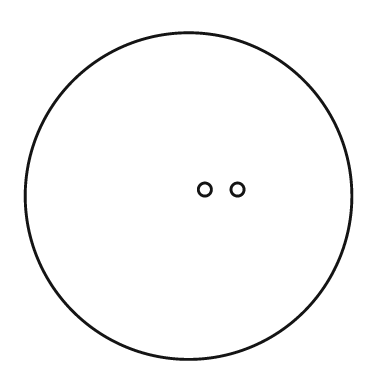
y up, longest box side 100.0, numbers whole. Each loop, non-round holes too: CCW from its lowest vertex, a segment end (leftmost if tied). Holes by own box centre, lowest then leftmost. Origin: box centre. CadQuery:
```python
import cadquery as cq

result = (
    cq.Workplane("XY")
    .moveTo(0.0, 0.0)
    .circle(50.0)
    .moveTo(5.0, 2.0)
    .circle(2.0)
    .moveTo(15.0, 2.0)
    .circle(2.0)
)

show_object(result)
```